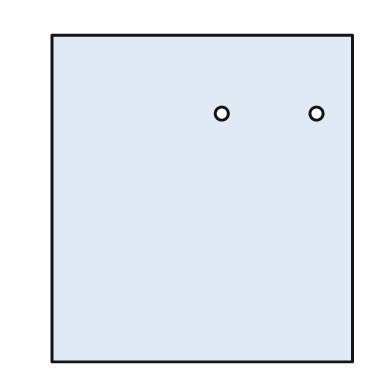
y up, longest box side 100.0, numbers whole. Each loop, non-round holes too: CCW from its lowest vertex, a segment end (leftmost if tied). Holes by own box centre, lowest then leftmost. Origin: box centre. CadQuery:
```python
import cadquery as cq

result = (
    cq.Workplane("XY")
    .moveTo(-46.0, -50.0)
    .lineTo(46.0, -50.0)
    .lineTo(46.0, 50.0)
    .lineTo(-46.0, 50.0)
    .close()
    .moveTo(6.0, 26.0)
    .circle(2.0)
    .moveTo(35.0, 26.0)
    .circle(2.0)
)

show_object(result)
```